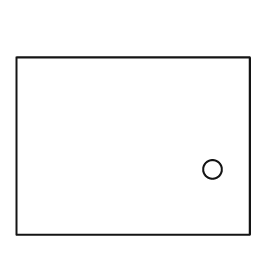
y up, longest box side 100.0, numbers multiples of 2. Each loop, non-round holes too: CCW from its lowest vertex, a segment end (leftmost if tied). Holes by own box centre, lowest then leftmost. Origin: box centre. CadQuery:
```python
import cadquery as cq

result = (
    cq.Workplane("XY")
    .moveTo(-50.0, -38.0)
    .lineTo(50.0, -38.0)
    .lineTo(50.0, 38.0)
    .lineTo(-50.0, 38.0)
    .close()
    .moveTo(34.0, -10.0)
    .circle(4.0)
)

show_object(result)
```